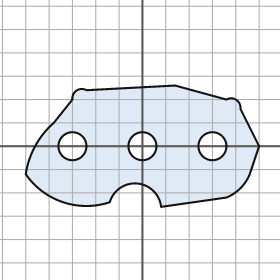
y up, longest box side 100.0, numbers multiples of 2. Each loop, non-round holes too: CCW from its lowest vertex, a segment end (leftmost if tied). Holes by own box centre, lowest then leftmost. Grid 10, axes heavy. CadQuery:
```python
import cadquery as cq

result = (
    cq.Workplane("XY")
    .moveTo(8.0, -26.0)
    .lineTo(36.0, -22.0)
    .threePointArc((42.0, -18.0), (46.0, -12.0))
    .lineTo(50.0, 0.0)
    .lineTo(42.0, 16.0)
    .threePointArc((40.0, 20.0), (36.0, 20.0))
    .lineTo(14.0, 26.0)
    .lineTo(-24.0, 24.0)
    .threePointArc((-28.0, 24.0), (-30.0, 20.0))
    .lineTo(-38.0, 10.0)
    .threePointArc((-46.0, 0.0), (-50.0, -12.0))
    .threePointArc((-34.0, -24.0), (-14.0, -24.0))
    .threePointArc((-2.0, -16.0), (8.0, -26.0))
    .close()
    .moveTo(-30.0, 0.0)
    .circle(6.0)
    .moveTo(0.0, 0.0)
    .circle(6.0)
    .moveTo(30.0, 0.0)
    .circle(6.0)
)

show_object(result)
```